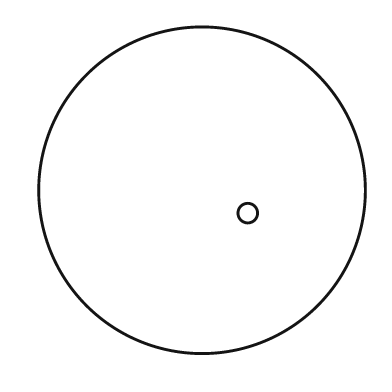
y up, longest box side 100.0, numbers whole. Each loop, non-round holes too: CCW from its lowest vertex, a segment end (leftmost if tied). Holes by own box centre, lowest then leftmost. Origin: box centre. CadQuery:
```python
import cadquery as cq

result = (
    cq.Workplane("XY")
    .moveTo(0.0, 0.0)
    .circle(50.0)
    .moveTo(14.0, -7.0)
    .circle(3.0)
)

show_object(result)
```